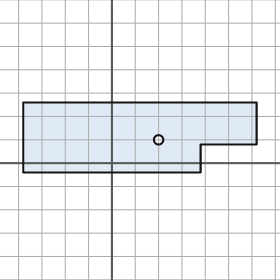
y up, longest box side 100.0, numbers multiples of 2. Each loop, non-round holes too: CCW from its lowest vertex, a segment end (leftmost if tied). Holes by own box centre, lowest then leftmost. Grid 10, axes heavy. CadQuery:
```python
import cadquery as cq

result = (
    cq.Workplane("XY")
    .moveTo(-38.0, -4.0)
    .lineTo(38.0, -4.0)
    .lineTo(38.0, 8.0)
    .lineTo(62.0, 8.0)
    .lineTo(62.0, 26.0)
    .lineTo(-38.0, 26.0)
    .close()
    .moveTo(20.0, 10.0)
    .circle(2.0)
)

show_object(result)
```